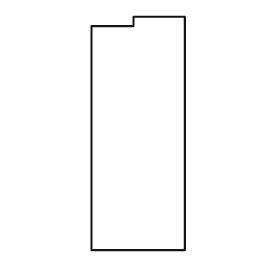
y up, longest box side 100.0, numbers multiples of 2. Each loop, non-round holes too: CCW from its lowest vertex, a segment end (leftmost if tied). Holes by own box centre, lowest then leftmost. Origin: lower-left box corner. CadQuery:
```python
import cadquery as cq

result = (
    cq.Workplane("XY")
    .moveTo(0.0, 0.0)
    .lineTo(40.0, 0.0)
    .lineTo(40.0, 100.0)
    .lineTo(18.0, 100.0)
    .lineTo(18.0, 96.0)
    .lineTo(0.0, 96.0)
    .close()
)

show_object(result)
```